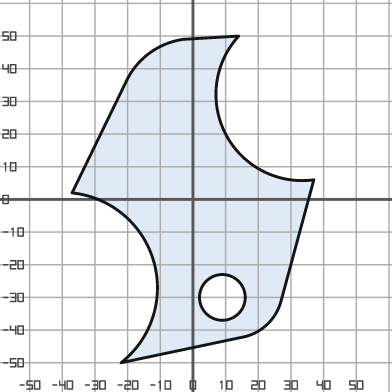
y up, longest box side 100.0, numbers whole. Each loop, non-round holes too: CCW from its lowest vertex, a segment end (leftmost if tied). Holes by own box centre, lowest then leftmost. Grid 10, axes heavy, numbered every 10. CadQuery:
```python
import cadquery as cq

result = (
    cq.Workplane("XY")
    .moveTo(-22.0, -50.0)
    .lineTo(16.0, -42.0)
    .threePointArc((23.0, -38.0), (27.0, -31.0))
    .lineTo(37.0, 6.0)
    .threePointArc((10.0, 20.0), (14.0, 50.0))
    .lineTo(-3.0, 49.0)
    .threePointArc((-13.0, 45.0), (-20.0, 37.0))
    .lineTo(-37.0, 2.0)
    .threePointArc((-12.0, -19.0), (-22.0, -50.0))
    .close()
    .moveTo(9.0, -30.0)
    .circle(7.0)
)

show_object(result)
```